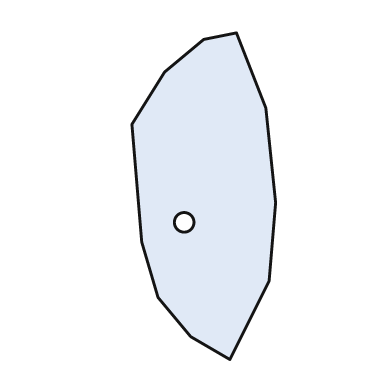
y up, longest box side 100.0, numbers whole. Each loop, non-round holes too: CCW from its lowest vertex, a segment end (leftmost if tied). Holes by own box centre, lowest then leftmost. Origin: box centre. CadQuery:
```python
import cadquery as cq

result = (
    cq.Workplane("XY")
    .moveTo(8.0, -50.0)
    .lineTo(20.0, -26.0)
    .lineTo(22.0, -2.0)
    .lineTo(19.0, 27.0)
    .lineTo(10.0, 50.0)
    .lineTo(0.0, 48.0)
    .lineTo(-12.0, 38.0)
    .lineTo(-22.0, 22.0)
    .lineTo(-19.0, -14.0)
    .lineTo(-14.0, -31.0)
    .lineTo(-4.0, -43.0)
    .close()
    .moveTo(-6.0, -8.0)
    .circle(3.0)
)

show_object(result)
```